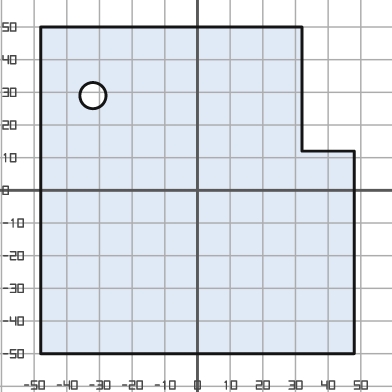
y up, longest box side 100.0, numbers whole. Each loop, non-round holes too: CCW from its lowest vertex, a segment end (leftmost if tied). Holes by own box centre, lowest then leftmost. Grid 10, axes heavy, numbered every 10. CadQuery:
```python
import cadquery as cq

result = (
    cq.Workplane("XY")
    .moveTo(-48.0, -50.0)
    .lineTo(48.0, -50.0)
    .lineTo(48.0, 12.0)
    .lineTo(32.0, 12.0)
    .lineTo(32.0, 50.0)
    .lineTo(-48.0, 50.0)
    .close()
    .moveTo(-32.0, 29.0)
    .circle(4.0)
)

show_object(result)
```